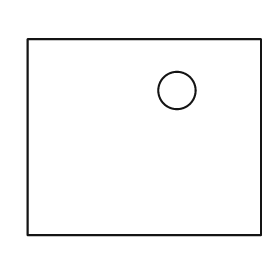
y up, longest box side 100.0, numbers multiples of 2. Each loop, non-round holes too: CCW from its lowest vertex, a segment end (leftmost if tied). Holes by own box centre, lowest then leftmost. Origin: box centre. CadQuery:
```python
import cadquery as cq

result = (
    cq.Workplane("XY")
    .moveTo(-50.0, -42.0)
    .lineTo(50.0, -42.0)
    .lineTo(50.0, 42.0)
    .lineTo(-50.0, 42.0)
    .close()
    .moveTo(14.0, 20.0)
    .circle(8.0)
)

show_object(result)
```